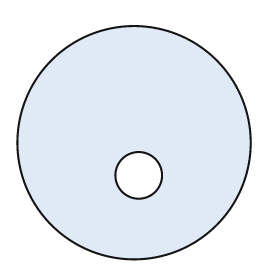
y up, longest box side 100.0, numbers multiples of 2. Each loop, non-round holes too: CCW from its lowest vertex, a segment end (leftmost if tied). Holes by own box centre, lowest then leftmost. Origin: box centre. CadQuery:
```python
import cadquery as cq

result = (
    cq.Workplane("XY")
    .moveTo(0.0, 0.0)
    .circle(50.0)
    .moveTo(2.0, -14.0)
    .circle(10.0)
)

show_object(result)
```